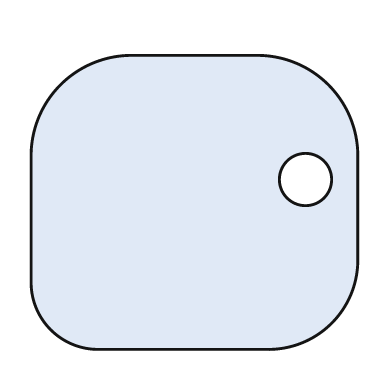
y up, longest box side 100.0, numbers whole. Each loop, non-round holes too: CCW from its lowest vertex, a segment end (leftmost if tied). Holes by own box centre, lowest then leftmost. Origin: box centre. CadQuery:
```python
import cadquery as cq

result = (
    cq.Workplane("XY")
    .moveTo(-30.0, -45.0)
    .lineTo(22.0, -45.0)
    .threePointArc((42.0, -37.0), (50.0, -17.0))
    .lineTo(50.0, 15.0)
    .threePointArc((41.0, 36.0), (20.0, 45.0))
    .lineTo(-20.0, 45.0)
    .threePointArc((-41.0, 36.0), (-50.0, 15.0))
    .lineTo(-50.0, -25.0)
    .threePointArc((-44.0, -39.0), (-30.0, -45.0))
    .close()
    .moveTo(34.0, 7.0)
    .circle(8.0)
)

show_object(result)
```